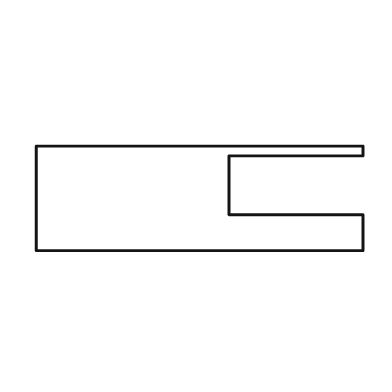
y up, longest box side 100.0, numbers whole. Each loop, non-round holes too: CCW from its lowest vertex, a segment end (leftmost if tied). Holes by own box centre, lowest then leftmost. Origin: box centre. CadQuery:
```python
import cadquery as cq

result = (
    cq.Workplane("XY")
    .moveTo(-50.0, -16.0)
    .lineTo(50.0, -16.0)
    .lineTo(50.0, -5.0)
    .lineTo(9.0, -5.0)
    .lineTo(9.0, 13.0)
    .lineTo(50.0, 13.0)
    .lineTo(50.0, 16.0)
    .lineTo(-50.0, 16.0)
    .close()
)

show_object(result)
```